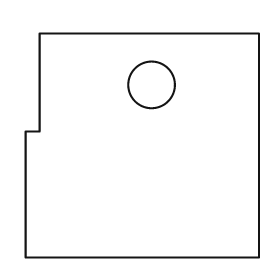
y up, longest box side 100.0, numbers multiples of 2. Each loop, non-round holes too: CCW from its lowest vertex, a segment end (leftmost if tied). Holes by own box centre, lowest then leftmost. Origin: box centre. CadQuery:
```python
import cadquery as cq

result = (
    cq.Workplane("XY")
    .moveTo(-50.0, -48.0)
    .lineTo(50.0, -48.0)
    .lineTo(50.0, 48.0)
    .lineTo(-44.0, 48.0)
    .lineTo(-44.0, 6.0)
    .lineTo(-50.0, 6.0)
    .close()
    .moveTo(4.0, 26.0)
    .circle(10.0)
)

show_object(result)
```